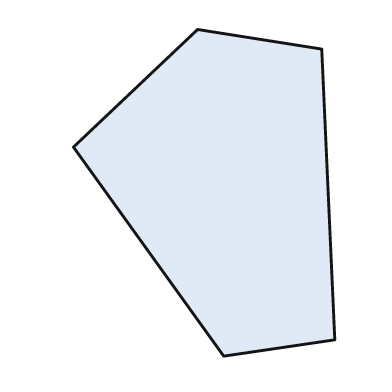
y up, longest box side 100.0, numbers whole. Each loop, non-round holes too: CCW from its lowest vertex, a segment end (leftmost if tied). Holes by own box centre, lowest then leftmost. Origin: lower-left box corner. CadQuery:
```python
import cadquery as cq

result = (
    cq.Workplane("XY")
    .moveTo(46.0, 0.0)
    .lineTo(80.0, 5.0)
    .lineTo(76.0, 94.0)
    .lineTo(38.0, 100.0)
    .lineTo(0.0, 64.0)
    .close()
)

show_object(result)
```